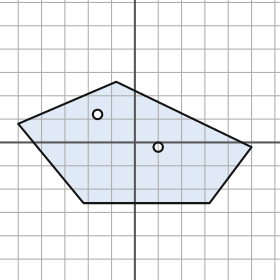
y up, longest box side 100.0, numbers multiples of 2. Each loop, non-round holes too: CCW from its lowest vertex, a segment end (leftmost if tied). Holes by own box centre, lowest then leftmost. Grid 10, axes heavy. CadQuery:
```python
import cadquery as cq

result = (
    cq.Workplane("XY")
    .moveTo(-22.0, -26.0)
    .lineTo(32.0, -26.0)
    .lineTo(50.0, -2.0)
    .lineTo(-8.0, 26.0)
    .lineTo(-50.0, 8.0)
    .close()
    .moveTo(10.0, -2.0)
    .circle(2.0)
    .moveTo(-16.0, 12.0)
    .circle(2.0)
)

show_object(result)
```